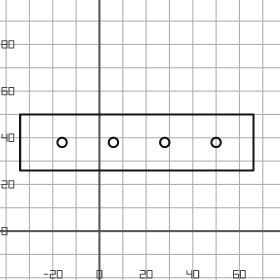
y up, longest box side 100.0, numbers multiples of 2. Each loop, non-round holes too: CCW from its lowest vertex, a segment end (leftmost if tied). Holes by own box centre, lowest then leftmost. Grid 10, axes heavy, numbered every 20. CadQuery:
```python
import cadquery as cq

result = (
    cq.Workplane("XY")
    .moveTo(-34.0, 26.0)
    .lineTo(66.0, 26.0)
    .lineTo(66.0, 50.0)
    .lineTo(-34.0, 50.0)
    .close()
    .moveTo(-16.0, 38.0)
    .circle(2.0)
    .moveTo(6.0, 38.0)
    .circle(2.0)
    .moveTo(28.0, 38.0)
    .circle(2.0)
    .moveTo(50.0, 38.0)
    .circle(2.0)
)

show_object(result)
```